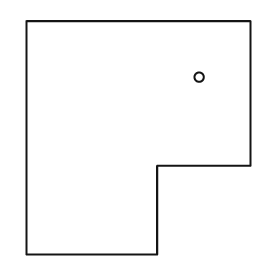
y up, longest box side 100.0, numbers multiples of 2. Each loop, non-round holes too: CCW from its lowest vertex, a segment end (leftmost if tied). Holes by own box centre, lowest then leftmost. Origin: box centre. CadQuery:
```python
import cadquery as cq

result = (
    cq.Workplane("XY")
    .moveTo(-48.0, -50.0)
    .lineTo(8.0, -50.0)
    .lineTo(8.0, -12.0)
    .lineTo(48.0, -12.0)
    .lineTo(48.0, 50.0)
    .lineTo(-48.0, 50.0)
    .close()
    .moveTo(26.0, 26.0)
    .circle(2.0)
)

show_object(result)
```